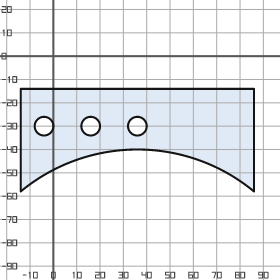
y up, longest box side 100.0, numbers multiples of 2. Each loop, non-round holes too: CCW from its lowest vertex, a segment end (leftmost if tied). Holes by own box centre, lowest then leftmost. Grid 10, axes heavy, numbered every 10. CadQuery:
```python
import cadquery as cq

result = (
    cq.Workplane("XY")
    .moveTo(-14.0, -58.0)
    .threePointArc((36.0, -40.0), (86.0, -58.0))
    .lineTo(86.0, -14.0)
    .lineTo(-14.0, -14.0)
    .close()
    .moveTo(-4.0, -30.0)
    .circle(4.0)
    .moveTo(16.0, -30.0)
    .circle(4.0)
    .moveTo(36.0, -30.0)
    .circle(4.0)
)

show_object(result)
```